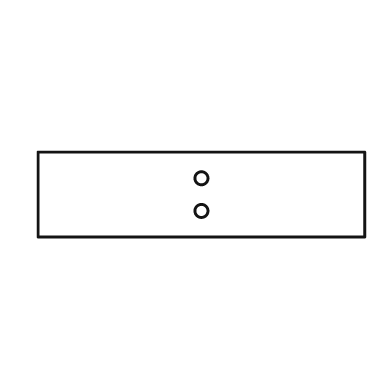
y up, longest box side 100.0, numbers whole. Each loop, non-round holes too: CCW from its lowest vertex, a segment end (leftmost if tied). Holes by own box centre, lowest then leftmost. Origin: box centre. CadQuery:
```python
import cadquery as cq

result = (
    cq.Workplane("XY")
    .moveTo(-50.0, -13.0)
    .lineTo(50.0, -13.0)
    .lineTo(50.0, 13.0)
    .lineTo(-50.0, 13.0)
    .close()
    .moveTo(0.0, -5.0)
    .circle(2.0)
    .moveTo(0.0, 5.0)
    .circle(2.0)
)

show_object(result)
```